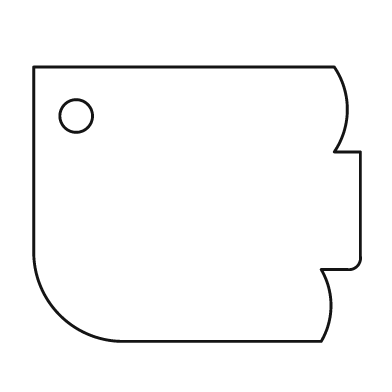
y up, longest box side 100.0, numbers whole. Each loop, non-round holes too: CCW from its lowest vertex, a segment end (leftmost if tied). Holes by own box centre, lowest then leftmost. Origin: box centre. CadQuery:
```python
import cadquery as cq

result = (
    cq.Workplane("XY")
    .moveTo(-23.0, -42.0)
    .lineTo(38.0, -42.0)
    .threePointArc((41.0, -31.0), (38.0, -20.0))
    .lineTo(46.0, -20.0)
    .threePointArc((49.0, -19.0), (50.0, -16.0))
    .lineTo(50.0, 16.0)
    .lineTo(42.0, 16.0)
    .threePointArc((46.0, 29.0), (42.0, 42.0))
    .lineTo(-50.0, 42.0)
    .lineTo(-50.0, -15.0)
    .threePointArc((-42.0, -34.0), (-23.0, -42.0))
    .close()
    .moveTo(-37.0, 27.0)
    .circle(5.0)
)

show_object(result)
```